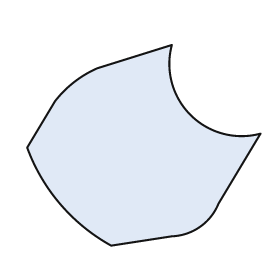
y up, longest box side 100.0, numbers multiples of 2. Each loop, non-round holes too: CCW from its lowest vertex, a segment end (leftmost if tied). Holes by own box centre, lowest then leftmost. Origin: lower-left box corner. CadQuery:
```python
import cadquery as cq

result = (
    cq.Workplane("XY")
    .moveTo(36.0, 0.0)
    .lineTo(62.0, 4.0)
    .threePointArc((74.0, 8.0), (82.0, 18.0))
    .lineTo(100.0, 48.0)
    .threePointArc((70.0, 56.0), (62.0, 86.0))
    .lineTo(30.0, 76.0)
    .threePointArc((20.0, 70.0), (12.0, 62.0))
    .lineTo(0.0, 42.0)
    .threePointArc((14.0, 18.0), (36.0, 0.0))
    .close()
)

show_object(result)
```